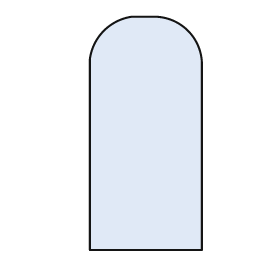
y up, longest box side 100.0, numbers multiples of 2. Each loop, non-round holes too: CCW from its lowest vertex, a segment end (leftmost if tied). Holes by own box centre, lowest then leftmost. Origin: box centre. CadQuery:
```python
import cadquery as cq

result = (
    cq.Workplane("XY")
    .moveTo(-24.0, -50.0)
    .lineTo(24.0, -50.0)
    .lineTo(24.0, 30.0)
    .threePointArc((18.0, 44.0), (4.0, 50.0))
    .lineTo(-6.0, 50.0)
    .threePointArc((-18.0, 44.0), (-24.0, 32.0))
    .close()
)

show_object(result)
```